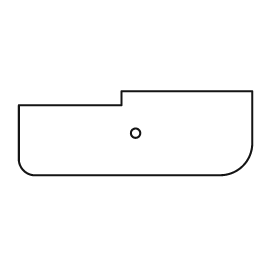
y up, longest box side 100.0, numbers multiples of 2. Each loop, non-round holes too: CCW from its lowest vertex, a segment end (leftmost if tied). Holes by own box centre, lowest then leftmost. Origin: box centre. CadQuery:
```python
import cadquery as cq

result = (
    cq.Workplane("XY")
    .moveTo(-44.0, -18.0)
    .lineTo(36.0, -18.0)
    .threePointArc((46.0, -14.0), (50.0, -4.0))
    .lineTo(50.0, 18.0)
    .lineTo(-6.0, 18.0)
    .lineTo(-6.0, 12.0)
    .lineTo(-50.0, 12.0)
    .lineTo(-50.0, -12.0)
    .threePointArc((-48.0, -16.0), (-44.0, -18.0))
    .close()
    .moveTo(0.0, 0.0)
    .circle(2.0)
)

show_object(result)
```